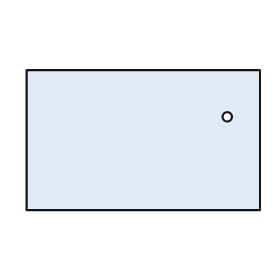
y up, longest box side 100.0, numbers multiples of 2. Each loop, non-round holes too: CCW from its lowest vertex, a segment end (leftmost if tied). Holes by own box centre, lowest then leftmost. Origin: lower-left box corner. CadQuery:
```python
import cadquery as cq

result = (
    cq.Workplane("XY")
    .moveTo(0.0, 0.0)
    .lineTo(100.0, 0.0)
    .lineTo(100.0, 60.0)
    .lineTo(0.0, 60.0)
    .close()
    .moveTo(86.0, 40.0)
    .circle(2.0)
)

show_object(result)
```